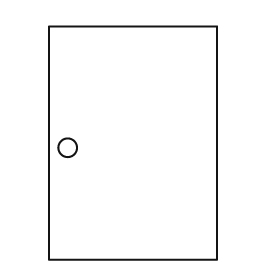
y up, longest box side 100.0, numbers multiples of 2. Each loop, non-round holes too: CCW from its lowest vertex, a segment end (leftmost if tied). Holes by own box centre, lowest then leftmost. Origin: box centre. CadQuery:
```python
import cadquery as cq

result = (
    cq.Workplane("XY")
    .moveTo(-36.0, -50.0)
    .lineTo(36.0, -50.0)
    .lineTo(36.0, 50.0)
    .lineTo(-36.0, 50.0)
    .close()
    .moveTo(-28.0, -2.0)
    .circle(4.0)
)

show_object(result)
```